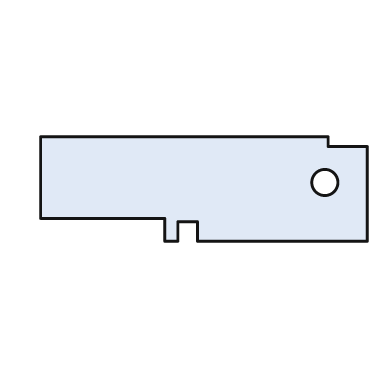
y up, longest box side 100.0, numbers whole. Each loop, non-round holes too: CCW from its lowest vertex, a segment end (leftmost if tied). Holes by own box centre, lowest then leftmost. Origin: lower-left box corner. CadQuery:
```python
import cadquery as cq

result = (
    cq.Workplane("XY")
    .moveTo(38.0, 0.0)
    .lineTo(42.0, 0.0)
    .lineTo(42.0, 6.0)
    .lineTo(48.0, 6.0)
    .lineTo(48.0, 0.0)
    .lineTo(100.0, 0.0)
    .lineTo(100.0, 29.0)
    .lineTo(88.0, 29.0)
    .lineTo(88.0, 32.0)
    .lineTo(0.0, 32.0)
    .lineTo(0.0, 7.0)
    .lineTo(38.0, 7.0)
    .close()
    .moveTo(87.0, 18.0)
    .circle(4.0)
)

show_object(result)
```